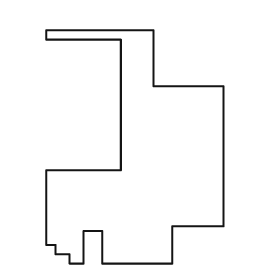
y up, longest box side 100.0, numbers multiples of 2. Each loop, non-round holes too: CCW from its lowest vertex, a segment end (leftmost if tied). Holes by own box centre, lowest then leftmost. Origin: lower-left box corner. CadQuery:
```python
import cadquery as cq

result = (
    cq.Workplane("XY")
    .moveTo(10.0, 0.0)
    .lineTo(16.0, 0.0)
    .lineTo(16.0, 14.0)
    .lineTo(24.0, 14.0)
    .lineTo(24.0, 0.0)
    .lineTo(54.0, 0.0)
    .lineTo(54.0, 16.0)
    .lineTo(76.0, 16.0)
    .lineTo(76.0, 76.0)
    .lineTo(46.0, 76.0)
    .lineTo(46.0, 100.0)
    .lineTo(0.0, 100.0)
    .lineTo(0.0, 96.0)
    .lineTo(32.0, 96.0)
    .lineTo(32.0, 40.0)
    .lineTo(0.0, 40.0)
    .lineTo(0.0, 8.0)
    .lineTo(4.0, 8.0)
    .lineTo(4.0, 4.0)
    .lineTo(10.0, 4.0)
    .close()
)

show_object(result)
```